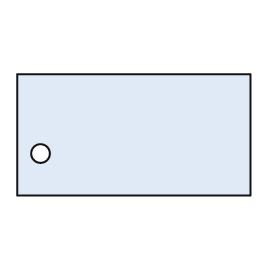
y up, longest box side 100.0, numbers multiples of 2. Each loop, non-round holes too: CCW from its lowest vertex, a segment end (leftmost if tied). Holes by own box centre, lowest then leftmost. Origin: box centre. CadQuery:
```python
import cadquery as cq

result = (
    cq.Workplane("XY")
    .moveTo(-50.0, -26.0)
    .lineTo(50.0, -26.0)
    .lineTo(50.0, 26.0)
    .lineTo(-50.0, 26.0)
    .close()
    .moveTo(-40.0, -8.0)
    .circle(4.0)
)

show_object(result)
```